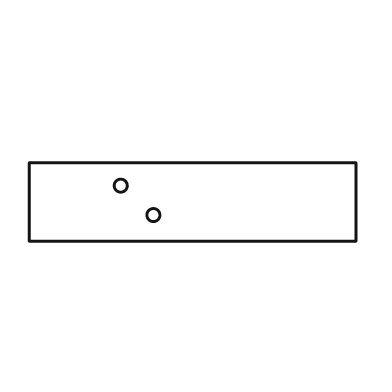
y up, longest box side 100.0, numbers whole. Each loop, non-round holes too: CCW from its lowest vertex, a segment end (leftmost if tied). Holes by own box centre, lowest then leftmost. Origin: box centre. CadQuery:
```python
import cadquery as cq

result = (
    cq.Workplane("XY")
    .moveTo(-50.0, -12.0)
    .lineTo(50.0, -12.0)
    .lineTo(50.0, 12.0)
    .lineTo(-50.0, 12.0)
    .close()
    .moveTo(-12.0, -4.0)
    .circle(2.0)
    .moveTo(-22.0, 5.0)
    .circle(2.0)
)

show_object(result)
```